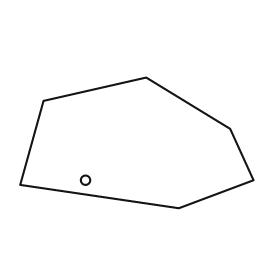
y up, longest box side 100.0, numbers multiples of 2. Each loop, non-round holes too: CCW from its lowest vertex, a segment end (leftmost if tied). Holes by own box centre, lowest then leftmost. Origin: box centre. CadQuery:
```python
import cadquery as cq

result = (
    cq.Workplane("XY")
    .moveTo(18.0, -28.0)
    .lineTo(50.0, -16.0)
    .lineTo(40.0, 6.0)
    .lineTo(4.0, 28.0)
    .lineTo(-40.0, 18.0)
    .lineTo(-50.0, -18.0)
    .close()
    .moveTo(-22.0, -16.0)
    .circle(2.0)
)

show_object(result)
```